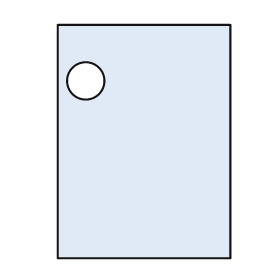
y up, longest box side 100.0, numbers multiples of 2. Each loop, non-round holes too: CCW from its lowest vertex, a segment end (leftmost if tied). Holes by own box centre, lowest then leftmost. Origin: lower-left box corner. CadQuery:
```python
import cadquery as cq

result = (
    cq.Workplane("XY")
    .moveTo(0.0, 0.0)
    .lineTo(74.0, 0.0)
    .lineTo(74.0, 100.0)
    .lineTo(0.0, 100.0)
    .close()
    .moveTo(12.0, 76.0)
    .circle(8.0)
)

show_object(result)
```